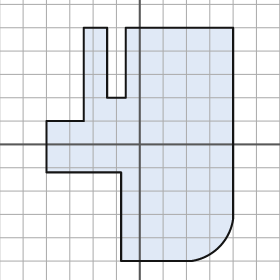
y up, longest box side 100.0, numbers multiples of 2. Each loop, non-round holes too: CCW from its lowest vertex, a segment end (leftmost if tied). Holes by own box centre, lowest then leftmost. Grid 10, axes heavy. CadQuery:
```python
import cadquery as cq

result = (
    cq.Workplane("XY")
    .moveTo(-8.0, -50.0)
    .lineTo(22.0, -50.0)
    .threePointArc((34.0, -44.0), (40.0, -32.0))
    .lineTo(40.0, 50.0)
    .lineTo(-6.0, 50.0)
    .lineTo(-6.0, 20.0)
    .lineTo(-14.0, 20.0)
    .lineTo(-14.0, 50.0)
    .lineTo(-24.0, 50.0)
    .lineTo(-24.0, 10.0)
    .lineTo(-40.0, 10.0)
    .lineTo(-40.0, -12.0)
    .lineTo(-8.0, -12.0)
    .close()
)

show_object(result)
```